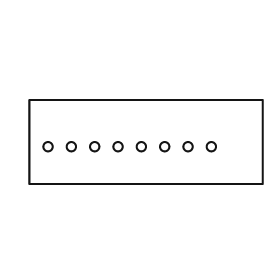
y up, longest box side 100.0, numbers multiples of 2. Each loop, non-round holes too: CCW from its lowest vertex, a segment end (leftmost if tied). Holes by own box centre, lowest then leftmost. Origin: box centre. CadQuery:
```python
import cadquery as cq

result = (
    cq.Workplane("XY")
    .moveTo(-50.0, -18.0)
    .lineTo(50.0, -18.0)
    .lineTo(50.0, 18.0)
    .lineTo(-50.0, 18.0)
    .close()
    .moveTo(-42.0, -2.0)
    .circle(2.0)
    .moveTo(-32.0, -2.0)
    .circle(2.0)
    .moveTo(-22.0, -2.0)
    .circle(2.0)
    .moveTo(-12.0, -2.0)
    .circle(2.0)
    .moveTo(-2.0, -2.0)
    .circle(2.0)
    .moveTo(8.0, -2.0)
    .circle(2.0)
    .moveTo(18.0, -2.0)
    .circle(2.0)
    .moveTo(28.0, -2.0)
    .circle(2.0)
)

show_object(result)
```